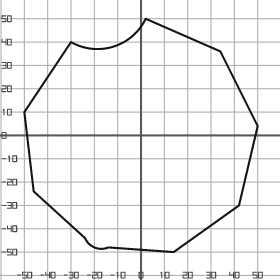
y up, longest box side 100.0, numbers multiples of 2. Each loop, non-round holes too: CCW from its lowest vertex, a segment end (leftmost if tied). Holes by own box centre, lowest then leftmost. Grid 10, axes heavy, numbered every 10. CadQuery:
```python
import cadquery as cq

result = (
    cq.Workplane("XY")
    .moveTo(14.0, -50.0)
    .lineTo(42.0, -30.0)
    .lineTo(50.0, 4.0)
    .lineTo(34.0, 36.0)
    .lineTo(2.0, 50.0)
    .threePointArc((-12.0, 38.0), (-30.0, 40.0))
    .lineTo(-50.0, 10.0)
    .lineTo(-46.0, -24.0)
    .lineTo(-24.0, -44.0)
    .threePointArc((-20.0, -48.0), (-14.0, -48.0))
    .close()
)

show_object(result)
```